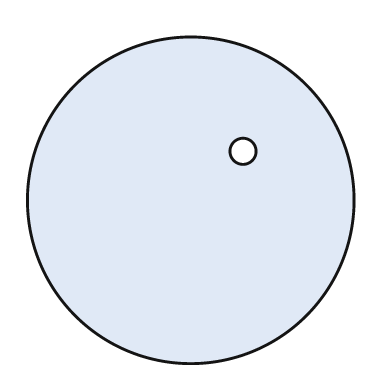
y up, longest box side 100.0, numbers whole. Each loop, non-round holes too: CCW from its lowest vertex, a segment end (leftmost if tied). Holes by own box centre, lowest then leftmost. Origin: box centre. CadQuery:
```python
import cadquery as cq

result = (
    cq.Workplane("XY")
    .moveTo(0.0, 0.0)
    .circle(50.0)
    .moveTo(16.0, 15.0)
    .circle(4.0)
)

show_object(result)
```